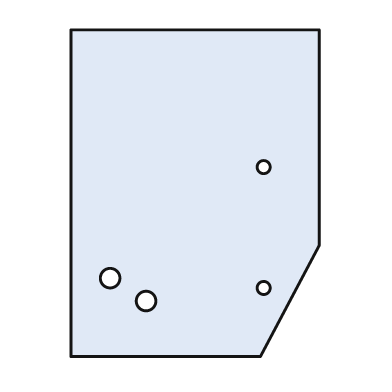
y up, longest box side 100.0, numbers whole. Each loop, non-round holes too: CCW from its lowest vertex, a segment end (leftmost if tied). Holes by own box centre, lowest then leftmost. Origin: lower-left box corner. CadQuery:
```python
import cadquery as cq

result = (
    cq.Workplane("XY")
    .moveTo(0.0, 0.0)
    .lineTo(58.0, 0.0)
    .lineTo(76.0, 34.0)
    .lineTo(76.0, 100.0)
    .lineTo(0.0, 100.0)
    .close()
    .moveTo(23.0, 17.0)
    .circle(3.0)
    .moveTo(59.0, 21.0)
    .circle(2.0)
    .moveTo(12.0, 24.0)
    .circle(3.0)
    .moveTo(59.0, 58.0)
    .circle(2.0)
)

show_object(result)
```